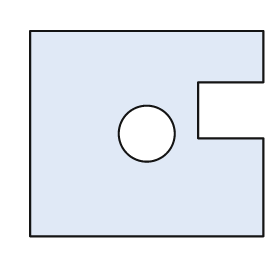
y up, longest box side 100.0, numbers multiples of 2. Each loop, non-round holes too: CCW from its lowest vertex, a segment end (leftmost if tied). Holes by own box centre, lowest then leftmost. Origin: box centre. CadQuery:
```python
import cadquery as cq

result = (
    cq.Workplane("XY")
    .moveTo(-50.0, -44.0)
    .lineTo(50.0, -44.0)
    .lineTo(50.0, -2.0)
    .lineTo(22.0, -2.0)
    .lineTo(22.0, 22.0)
    .lineTo(50.0, 22.0)
    .lineTo(50.0, 44.0)
    .lineTo(-50.0, 44.0)
    .close()
    .moveTo(0.0, 0.0)
    .circle(12.0)
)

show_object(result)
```